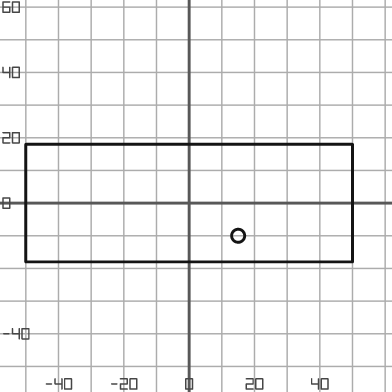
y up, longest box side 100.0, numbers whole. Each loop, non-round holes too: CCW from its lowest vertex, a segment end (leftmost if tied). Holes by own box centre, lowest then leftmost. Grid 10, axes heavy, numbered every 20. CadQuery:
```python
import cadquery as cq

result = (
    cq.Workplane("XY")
    .moveTo(-50.0, -18.0)
    .lineTo(50.0, -18.0)
    .lineTo(50.0, 18.0)
    .lineTo(-50.0, 18.0)
    .close()
    .moveTo(15.0, -10.0)
    .circle(2.0)
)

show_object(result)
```